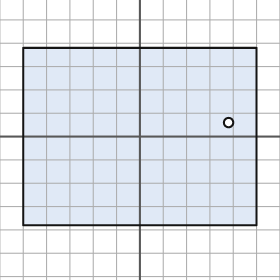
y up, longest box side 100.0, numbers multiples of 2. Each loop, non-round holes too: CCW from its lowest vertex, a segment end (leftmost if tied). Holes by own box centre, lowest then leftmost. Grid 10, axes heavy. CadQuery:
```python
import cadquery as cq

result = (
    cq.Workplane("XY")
    .moveTo(-50.0, -38.0)
    .lineTo(50.0, -38.0)
    .lineTo(50.0, 38.0)
    .lineTo(-50.0, 38.0)
    .close()
    .moveTo(38.0, 6.0)
    .circle(2.0)
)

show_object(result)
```